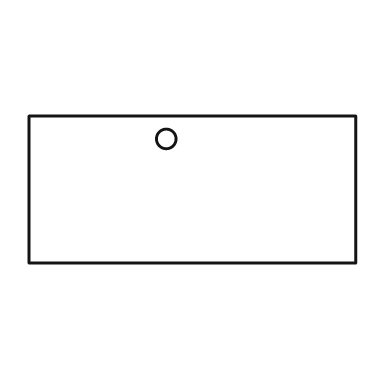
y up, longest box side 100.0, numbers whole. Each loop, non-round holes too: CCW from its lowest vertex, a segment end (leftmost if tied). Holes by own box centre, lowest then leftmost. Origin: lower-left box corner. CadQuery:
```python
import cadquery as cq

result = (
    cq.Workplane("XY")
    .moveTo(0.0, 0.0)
    .lineTo(100.0, 0.0)
    .lineTo(100.0, 45.0)
    .lineTo(0.0, 45.0)
    .close()
    .moveTo(42.0, 38.0)
    .circle(3.0)
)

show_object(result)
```